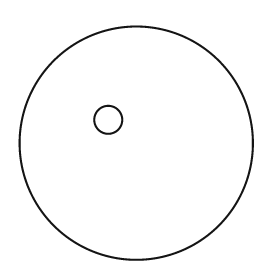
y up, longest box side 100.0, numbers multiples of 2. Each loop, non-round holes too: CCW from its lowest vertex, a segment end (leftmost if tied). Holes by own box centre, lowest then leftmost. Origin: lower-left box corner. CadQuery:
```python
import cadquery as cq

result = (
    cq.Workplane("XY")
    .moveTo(50.0, 50.0)
    .circle(50.0)
    .moveTo(38.0, 60.0)
    .circle(6.0)
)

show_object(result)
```